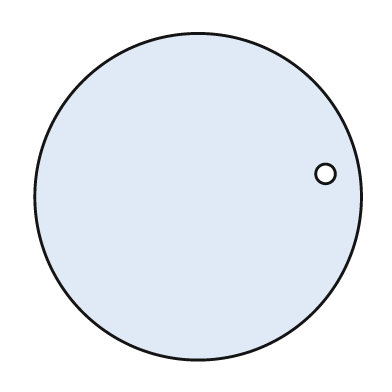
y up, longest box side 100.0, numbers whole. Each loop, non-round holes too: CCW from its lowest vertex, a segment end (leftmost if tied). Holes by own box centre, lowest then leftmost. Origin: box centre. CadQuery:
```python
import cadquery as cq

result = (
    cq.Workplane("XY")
    .moveTo(0.0, 0.0)
    .circle(50.0)
    .moveTo(39.0, 7.0)
    .circle(3.0)
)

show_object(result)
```